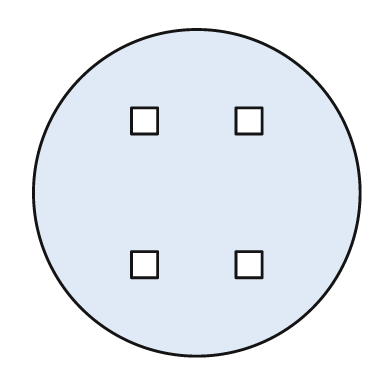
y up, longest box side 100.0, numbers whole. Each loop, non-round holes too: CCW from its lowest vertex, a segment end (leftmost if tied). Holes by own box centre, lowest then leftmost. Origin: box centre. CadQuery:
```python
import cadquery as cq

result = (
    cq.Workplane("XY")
    .moveTo(0.0, 0.0)
    .circle(50.0)
    .moveTo(-20.0, -26.0)
    .lineTo(-12.0, -26.0)
    .lineTo(-12.0, -18.0)
    .lineTo(-20.0, -18.0)
    .close()
    .moveTo(12.0, -26.0)
    .lineTo(20.0, -26.0)
    .lineTo(20.0, -18.0)
    .lineTo(12.0, -18.0)
    .close()
    .moveTo(-20.0, 18.0)
    .lineTo(-12.0, 18.0)
    .lineTo(-12.0, 26.0)
    .lineTo(-20.0, 26.0)
    .close()
    .moveTo(12.0, 18.0)
    .lineTo(20.0, 18.0)
    .lineTo(20.0, 26.0)
    .lineTo(12.0, 26.0)
    .close()
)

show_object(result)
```